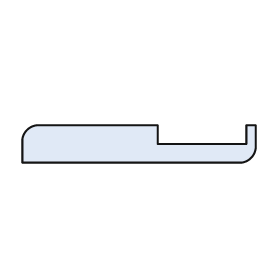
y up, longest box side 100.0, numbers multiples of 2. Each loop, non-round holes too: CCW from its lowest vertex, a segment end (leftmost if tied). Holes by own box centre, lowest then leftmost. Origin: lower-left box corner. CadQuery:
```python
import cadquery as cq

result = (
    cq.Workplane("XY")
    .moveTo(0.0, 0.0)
    .lineTo(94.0, 0.0)
    .threePointArc((98.0, 2.0), (100.0, 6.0))
    .lineTo(100.0, 16.0)
    .lineTo(96.0, 16.0)
    .lineTo(96.0, 8.0)
    .lineTo(58.0, 8.0)
    .lineTo(58.0, 16.0)
    .lineTo(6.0, 16.0)
    .threePointArc((2.0, 14.0), (0.0, 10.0))
    .close()
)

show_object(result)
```